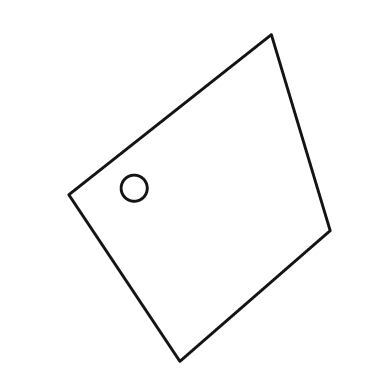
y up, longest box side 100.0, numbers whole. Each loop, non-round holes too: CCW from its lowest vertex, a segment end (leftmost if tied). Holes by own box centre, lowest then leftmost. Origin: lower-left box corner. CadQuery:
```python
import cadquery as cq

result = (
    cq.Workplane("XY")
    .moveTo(34.0, 0.0)
    .lineTo(80.0, 40.0)
    .lineTo(62.0, 100.0)
    .lineTo(0.0, 51.0)
    .close()
    .moveTo(20.0, 53.0)
    .circle(4.0)
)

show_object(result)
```